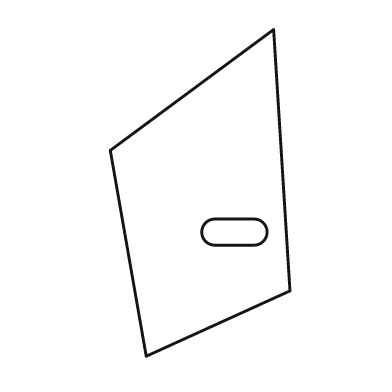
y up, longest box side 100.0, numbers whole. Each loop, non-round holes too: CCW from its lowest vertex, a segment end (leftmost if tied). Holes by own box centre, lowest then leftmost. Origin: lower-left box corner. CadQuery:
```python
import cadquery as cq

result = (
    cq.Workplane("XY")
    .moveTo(11.0, 0.0)
    .lineTo(55.0, 20.0)
    .lineTo(50.0, 100.0)
    .lineTo(0.0, 63.0)
    .close()
    .moveTo(32.0, 34.0)
    .lineTo(44.0, 34.0)
    .threePointArc((48.0, 38.0), (44.0, 42.0))
    .lineTo(32.0, 42.0)
    .threePointArc((28.0, 38.0), (32.0, 34.0))
    .close()
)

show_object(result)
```